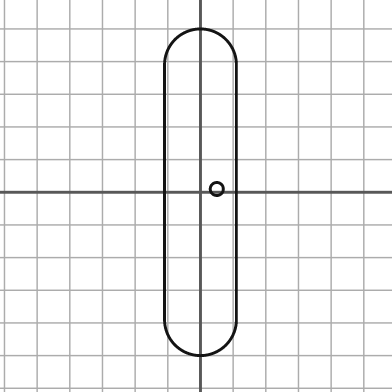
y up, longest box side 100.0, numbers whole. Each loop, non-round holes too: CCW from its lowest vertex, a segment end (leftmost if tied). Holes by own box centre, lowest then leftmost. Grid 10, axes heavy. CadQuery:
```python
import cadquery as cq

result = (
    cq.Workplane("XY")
    .moveTo(-11.0, -39.0)
    .threePointArc((0.0, -50.0), (11.0, -39.0))
    .lineTo(11.0, 39.0)
    .threePointArc((0.0, 50.0), (-11.0, 39.0))
    .close()
    .moveTo(5.0, 1.0)
    .circle(2.0)
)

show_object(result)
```